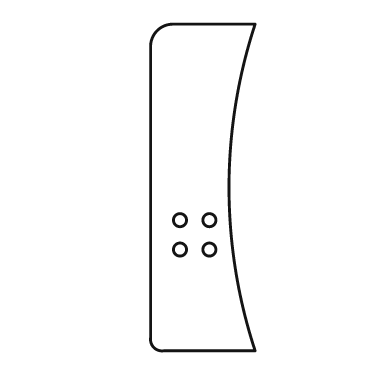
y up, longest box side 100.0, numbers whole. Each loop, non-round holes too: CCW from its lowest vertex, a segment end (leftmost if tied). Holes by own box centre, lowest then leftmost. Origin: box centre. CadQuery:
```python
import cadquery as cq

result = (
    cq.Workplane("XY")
    .moveTo(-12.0, -50.0)
    .lineTo(16.0, -50.0)
    .threePointArc((8.0, 0.0), (16.0, 50.0))
    .lineTo(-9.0, 50.0)
    .threePointArc((-14.0, 48.0), (-16.0, 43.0))
    .lineTo(-16.0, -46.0)
    .threePointArc((-15.0, -49.0), (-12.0, -50.0))
    .close()
    .moveTo(-7.0, -19.0)
    .circle(2.0)
    .moveTo(2.0, -19.0)
    .circle(2.0)
    .moveTo(-7.0, -10.0)
    .circle(2.0)
    .moveTo(2.0, -10.0)
    .circle(2.0)
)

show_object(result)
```